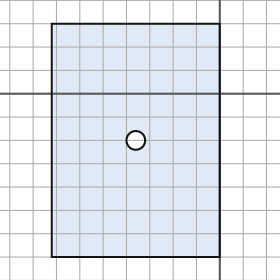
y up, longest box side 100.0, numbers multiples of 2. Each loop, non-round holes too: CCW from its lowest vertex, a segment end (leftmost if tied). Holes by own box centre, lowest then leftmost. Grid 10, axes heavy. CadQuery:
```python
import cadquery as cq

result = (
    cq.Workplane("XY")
    .moveTo(-72.0, -70.0)
    .lineTo(0.0, -70.0)
    .lineTo(0.0, 30.0)
    .lineTo(-72.0, 30.0)
    .close()
    .moveTo(-36.0, -20.0)
    .circle(4.0)
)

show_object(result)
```